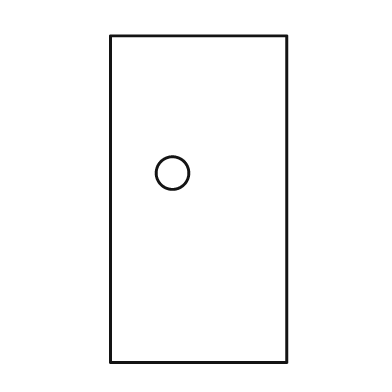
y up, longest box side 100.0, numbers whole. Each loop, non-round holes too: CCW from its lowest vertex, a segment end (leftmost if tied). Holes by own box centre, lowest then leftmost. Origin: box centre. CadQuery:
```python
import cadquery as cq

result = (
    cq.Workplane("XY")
    .moveTo(-27.0, -50.0)
    .lineTo(27.0, -50.0)
    .lineTo(27.0, 50.0)
    .lineTo(-27.0, 50.0)
    .close()
    .moveTo(-8.0, 8.0)
    .circle(5.0)
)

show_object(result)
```